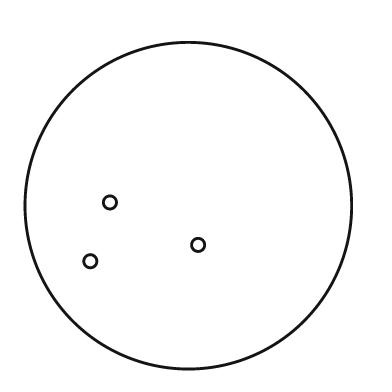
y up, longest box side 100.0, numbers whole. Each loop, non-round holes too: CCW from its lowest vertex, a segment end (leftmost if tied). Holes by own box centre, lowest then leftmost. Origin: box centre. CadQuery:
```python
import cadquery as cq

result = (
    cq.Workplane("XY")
    .moveTo(0.0, 0.0)
    .circle(50.0)
    .moveTo(-30.0, -17.0)
    .circle(2.0)
    .moveTo(3.0, -12.0)
    .circle(2.0)
    .moveTo(-24.0, 1.0)
    .circle(2.0)
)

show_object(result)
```